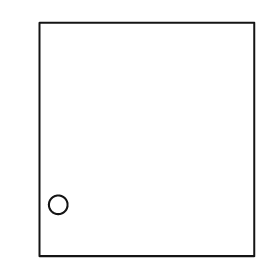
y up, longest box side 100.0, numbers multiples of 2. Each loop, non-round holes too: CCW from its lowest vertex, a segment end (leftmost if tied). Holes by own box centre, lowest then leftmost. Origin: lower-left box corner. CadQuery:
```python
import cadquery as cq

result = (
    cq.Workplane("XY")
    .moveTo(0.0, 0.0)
    .lineTo(92.0, 0.0)
    .lineTo(92.0, 100.0)
    .lineTo(0.0, 100.0)
    .close()
    .moveTo(8.0, 22.0)
    .circle(4.0)
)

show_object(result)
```